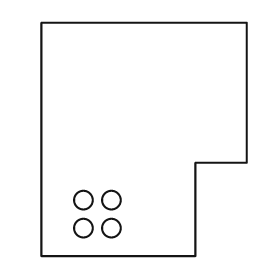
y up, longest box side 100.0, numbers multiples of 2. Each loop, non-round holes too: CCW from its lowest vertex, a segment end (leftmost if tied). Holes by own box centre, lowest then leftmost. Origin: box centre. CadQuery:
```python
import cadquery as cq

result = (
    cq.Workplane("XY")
    .moveTo(-44.0, -50.0)
    .lineTo(22.0, -50.0)
    .lineTo(22.0, -10.0)
    .lineTo(44.0, -10.0)
    .lineTo(44.0, 50.0)
    .lineTo(-44.0, 50.0)
    .close()
    .moveTo(-26.0, -38.0)
    .circle(4.0)
    .moveTo(-14.0, -38.0)
    .circle(4.0)
    .moveTo(-26.0, -26.0)
    .circle(4.0)
    .moveTo(-14.0, -26.0)
    .circle(4.0)
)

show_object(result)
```